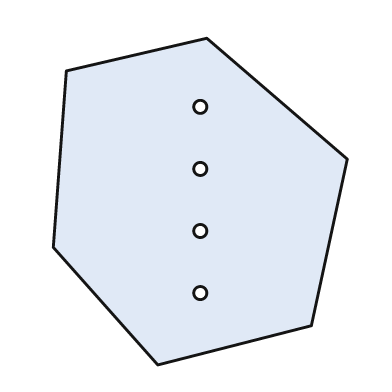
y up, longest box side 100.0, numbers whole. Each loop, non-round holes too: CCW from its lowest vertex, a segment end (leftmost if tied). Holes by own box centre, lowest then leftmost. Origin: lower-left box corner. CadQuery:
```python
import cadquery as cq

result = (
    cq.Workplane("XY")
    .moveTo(32.0, 0.0)
    .lineTo(79.0, 12.0)
    .lineTo(90.0, 63.0)
    .lineTo(47.0, 100.0)
    .lineTo(4.0, 90.0)
    .lineTo(0.0, 36.0)
    .close()
    .moveTo(45.0, 22.0)
    .circle(2.0)
    .moveTo(45.0, 41.0)
    .circle(2.0)
    .moveTo(45.0, 60.0)
    .circle(2.0)
    .moveTo(45.0, 79.0)
    .circle(2.0)
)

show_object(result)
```